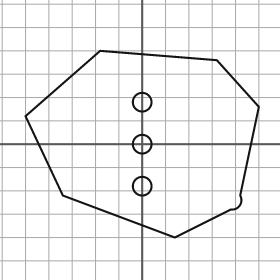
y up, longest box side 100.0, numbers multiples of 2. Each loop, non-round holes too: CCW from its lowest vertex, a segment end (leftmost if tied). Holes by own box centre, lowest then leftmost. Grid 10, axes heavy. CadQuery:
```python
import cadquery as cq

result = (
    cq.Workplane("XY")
    .moveTo(14.0, -40.0)
    .lineTo(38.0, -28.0)
    .threePointArc((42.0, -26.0), (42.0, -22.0))
    .lineTo(50.0, 16.0)
    .lineTo(32.0, 36.0)
    .lineTo(-18.0, 40.0)
    .lineTo(-50.0, 12.0)
    .lineTo(-34.0, -22.0)
    .close()
    .moveTo(0.0, -18.0)
    .circle(4.0)
    .moveTo(0.0, 0.0)
    .circle(4.0)
    .moveTo(0.0, 18.0)
    .circle(4.0)
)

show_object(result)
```